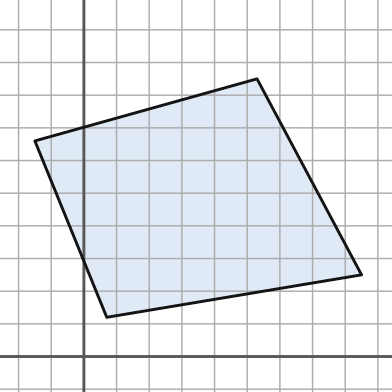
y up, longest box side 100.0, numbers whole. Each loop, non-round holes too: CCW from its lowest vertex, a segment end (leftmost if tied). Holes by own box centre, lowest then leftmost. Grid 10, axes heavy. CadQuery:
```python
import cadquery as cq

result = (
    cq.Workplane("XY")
    .moveTo(7.0, 12.0)
    .lineTo(85.0, 25.0)
    .lineTo(53.0, 85.0)
    .lineTo(-15.0, 66.0)
    .close()
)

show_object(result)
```